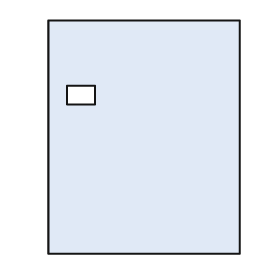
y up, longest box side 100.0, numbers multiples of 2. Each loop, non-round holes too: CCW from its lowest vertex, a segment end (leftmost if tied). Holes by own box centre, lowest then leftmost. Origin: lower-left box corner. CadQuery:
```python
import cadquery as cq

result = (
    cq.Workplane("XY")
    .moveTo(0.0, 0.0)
    .lineTo(82.0, 0.0)
    .lineTo(82.0, 100.0)
    .lineTo(0.0, 100.0)
    .close()
    .moveTo(8.0, 64.0)
    .lineTo(20.0, 64.0)
    .lineTo(20.0, 72.0)
    .lineTo(8.0, 72.0)
    .close()
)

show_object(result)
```